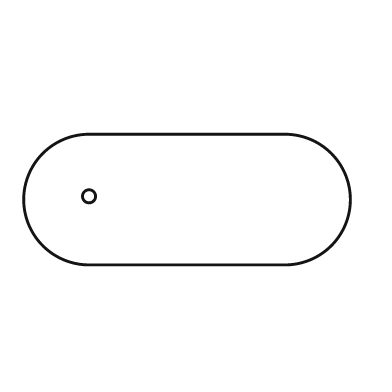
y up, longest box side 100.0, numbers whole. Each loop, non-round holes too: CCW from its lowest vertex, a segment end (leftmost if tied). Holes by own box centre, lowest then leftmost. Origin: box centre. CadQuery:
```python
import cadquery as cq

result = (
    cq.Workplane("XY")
    .moveTo(-30.0, -20.0)
    .lineTo(30.0, -20.0)
    .threePointArc((50.0, 0.0), (30.0, 20.0))
    .lineTo(-30.0, 20.0)
    .threePointArc((-50.0, 0.0), (-30.0, -20.0))
    .close()
    .moveTo(-30.0, 1.0)
    .circle(2.0)
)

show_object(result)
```